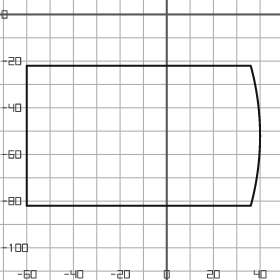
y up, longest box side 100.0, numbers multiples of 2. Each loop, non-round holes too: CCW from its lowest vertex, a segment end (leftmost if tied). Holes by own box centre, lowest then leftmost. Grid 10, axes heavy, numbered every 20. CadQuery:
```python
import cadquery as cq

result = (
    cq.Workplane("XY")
    .moveTo(-60.0, -82.0)
    .lineTo(36.0, -82.0)
    .threePointArc((40.0, -52.0), (36.0, -22.0))
    .lineTo(-60.0, -22.0)
    .close()
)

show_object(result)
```